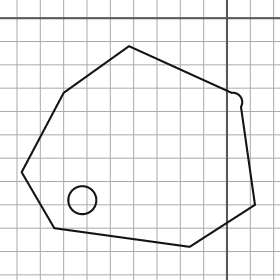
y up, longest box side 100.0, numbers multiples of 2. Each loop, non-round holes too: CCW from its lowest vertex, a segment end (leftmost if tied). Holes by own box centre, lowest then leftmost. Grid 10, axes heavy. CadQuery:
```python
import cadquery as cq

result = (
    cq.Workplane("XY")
    .moveTo(-16.0, -98.0)
    .lineTo(12.0, -80.0)
    .lineTo(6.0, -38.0)
    .threePointArc((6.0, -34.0), (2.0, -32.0))
    .lineTo(-42.0, -12.0)
    .lineTo(-70.0, -32.0)
    .lineTo(-88.0, -66.0)
    .lineTo(-74.0, -90.0)
    .close()
    .moveTo(-62.0, -78.0)
    .circle(6.0)
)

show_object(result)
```